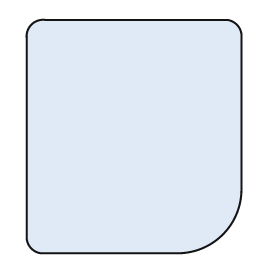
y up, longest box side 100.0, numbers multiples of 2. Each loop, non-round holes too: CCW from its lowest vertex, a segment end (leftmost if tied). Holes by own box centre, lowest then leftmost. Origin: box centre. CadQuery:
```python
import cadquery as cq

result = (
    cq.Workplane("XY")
    .moveTo(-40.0, -50.0)
    .lineTo(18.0, -50.0)
    .threePointArc((38.0, -42.0), (46.0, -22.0))
    .lineTo(46.0, 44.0)
    .threePointArc((44.0, 48.0), (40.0, 50.0))
    .lineTo(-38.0, 50.0)
    .threePointArc((-44.0, 48.0), (-46.0, 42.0))
    .lineTo(-46.0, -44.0)
    .threePointArc((-44.0, -48.0), (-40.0, -50.0))
    .close()
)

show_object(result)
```